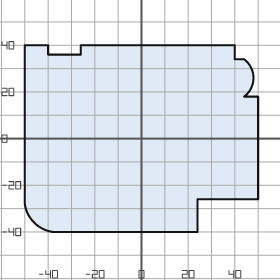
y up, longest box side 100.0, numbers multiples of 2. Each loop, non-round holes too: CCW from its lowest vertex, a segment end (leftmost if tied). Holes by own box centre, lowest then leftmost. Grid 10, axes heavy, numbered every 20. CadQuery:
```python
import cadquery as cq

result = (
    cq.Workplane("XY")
    .moveTo(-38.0, -40.0)
    .lineTo(24.0, -40.0)
    .lineTo(24.0, -26.0)
    .lineTo(50.0, -26.0)
    .lineTo(50.0, 18.0)
    .lineTo(44.0, 18.0)
    .threePointArc((48.0, 26.0), (44.0, 34.0))
    .lineTo(40.0, 34.0)
    .lineTo(40.0, 40.0)
    .lineTo(-26.0, 40.0)
    .lineTo(-26.0, 36.0)
    .lineTo(-40.0, 36.0)
    .lineTo(-40.0, 40.0)
    .lineTo(-50.0, 40.0)
    .lineTo(-50.0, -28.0)
    .threePointArc((-46.0, -36.0), (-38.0, -40.0))
    .close()
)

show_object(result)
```